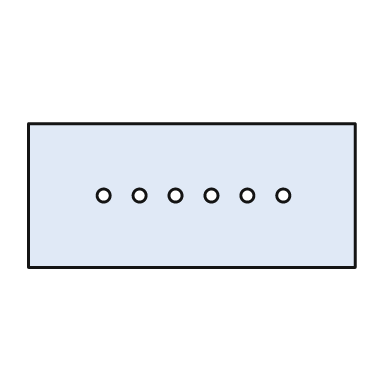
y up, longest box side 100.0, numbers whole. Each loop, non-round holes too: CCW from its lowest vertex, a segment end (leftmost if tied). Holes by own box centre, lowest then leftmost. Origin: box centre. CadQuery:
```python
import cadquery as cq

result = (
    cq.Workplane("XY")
    .moveTo(-50.0, -22.0)
    .lineTo(50.0, -22.0)
    .lineTo(50.0, 22.0)
    .lineTo(-50.0, 22.0)
    .close()
    .moveTo(-27.0, 0.0)
    .circle(2.0)
    .moveTo(-16.0, 0.0)
    .circle(2.0)
    .moveTo(-5.0, 0.0)
    .circle(2.0)
    .moveTo(6.0, 0.0)
    .circle(2.0)
    .moveTo(17.0, 0.0)
    .circle(2.0)
    .moveTo(28.0, 0.0)
    .circle(2.0)
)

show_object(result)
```